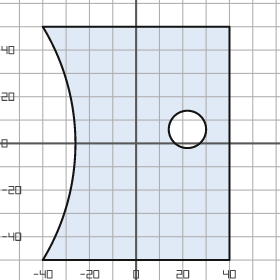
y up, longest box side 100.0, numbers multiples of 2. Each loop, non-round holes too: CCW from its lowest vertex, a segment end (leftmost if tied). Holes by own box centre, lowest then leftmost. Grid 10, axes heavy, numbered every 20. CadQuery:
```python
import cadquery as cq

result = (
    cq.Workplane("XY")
    .moveTo(-40.0, -50.0)
    .lineTo(40.0, -50.0)
    .lineTo(40.0, 50.0)
    .lineTo(-40.0, 50.0)
    .threePointArc((-26.0, 0.0), (-40.0, -50.0))
    .close()
    .moveTo(22.0, 6.0)
    .circle(8.0)
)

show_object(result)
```